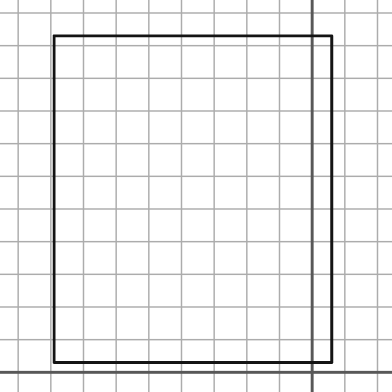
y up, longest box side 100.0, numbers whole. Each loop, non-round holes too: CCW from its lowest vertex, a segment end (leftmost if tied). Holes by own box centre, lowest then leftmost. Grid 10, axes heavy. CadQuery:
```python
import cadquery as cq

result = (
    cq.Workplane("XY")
    .moveTo(-79.0, 3.0)
    .lineTo(6.0, 3.0)
    .lineTo(6.0, 103.0)
    .lineTo(-79.0, 103.0)
    .close()
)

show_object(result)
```